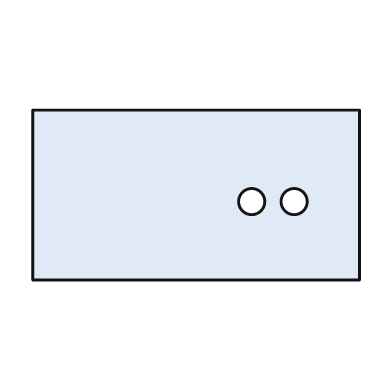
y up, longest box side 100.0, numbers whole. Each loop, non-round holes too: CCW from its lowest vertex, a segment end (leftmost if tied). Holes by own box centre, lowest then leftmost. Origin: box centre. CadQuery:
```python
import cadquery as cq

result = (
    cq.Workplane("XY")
    .moveTo(-50.0, -26.0)
    .lineTo(50.0, -26.0)
    .lineTo(50.0, 26.0)
    .lineTo(-50.0, 26.0)
    .close()
    .moveTo(17.0, -2.0)
    .circle(4.0)
    .moveTo(30.0, -2.0)
    .circle(4.0)
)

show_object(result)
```